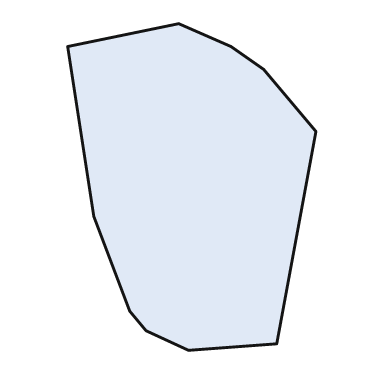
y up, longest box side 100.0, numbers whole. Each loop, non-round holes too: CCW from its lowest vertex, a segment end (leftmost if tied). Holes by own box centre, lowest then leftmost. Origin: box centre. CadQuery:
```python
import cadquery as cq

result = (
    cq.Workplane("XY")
    .moveTo(-1.0, -50.0)
    .lineTo(26.0, -48.0)
    .lineTo(38.0, 17.0)
    .lineTo(22.0, 36.0)
    .lineTo(12.0, 43.0)
    .lineTo(-4.0, 50.0)
    .lineTo(-38.0, 43.0)
    .lineTo(-30.0, -9.0)
    .lineTo(-19.0, -38.0)
    .lineTo(-14.0, -44.0)
    .close()
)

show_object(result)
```